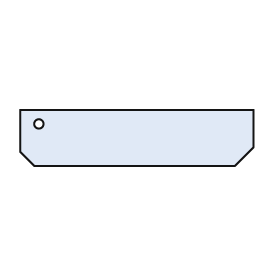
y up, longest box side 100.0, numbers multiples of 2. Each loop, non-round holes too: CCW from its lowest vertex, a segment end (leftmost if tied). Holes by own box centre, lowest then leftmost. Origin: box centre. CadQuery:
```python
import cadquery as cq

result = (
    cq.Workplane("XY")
    .moveTo(-44.0, -12.0)
    .lineTo(42.0, -12.0)
    .lineTo(50.0, -4.0)
    .lineTo(50.0, 12.0)
    .lineTo(-50.0, 12.0)
    .lineTo(-50.0, -6.0)
    .close()
    .moveTo(-42.0, 6.0)
    .circle(2.0)
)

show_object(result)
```